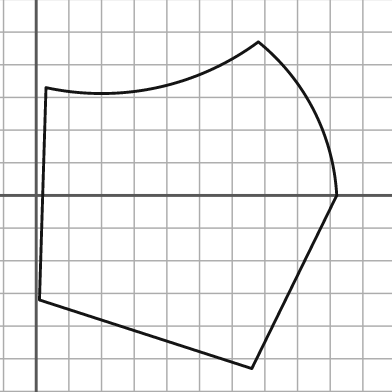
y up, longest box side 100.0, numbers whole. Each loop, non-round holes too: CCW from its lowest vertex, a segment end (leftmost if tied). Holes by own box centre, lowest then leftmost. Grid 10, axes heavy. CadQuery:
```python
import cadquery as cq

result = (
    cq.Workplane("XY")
    .moveTo(66.0, -53.0)
    .lineTo(92.0, 0.0)
    .threePointArc((85.0, 26.0), (68.0, 47.0))
    .threePointArc((37.0, 33.0), (3.0, 33.0))
    .lineTo(1.0, -32.0)
    .close()
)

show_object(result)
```